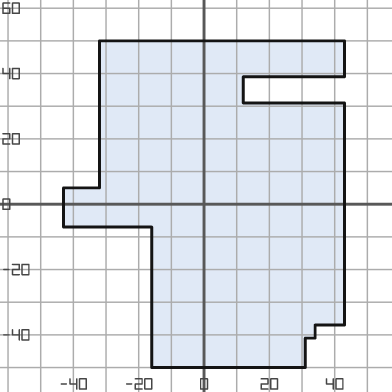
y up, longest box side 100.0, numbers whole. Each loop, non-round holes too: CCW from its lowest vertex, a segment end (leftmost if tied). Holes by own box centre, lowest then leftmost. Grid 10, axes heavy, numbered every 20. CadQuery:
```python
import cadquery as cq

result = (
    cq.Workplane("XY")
    .moveTo(-16.0, -50.0)
    .lineTo(31.0, -50.0)
    .lineTo(31.0, -41.0)
    .lineTo(34.0, -41.0)
    .lineTo(34.0, -37.0)
    .lineTo(43.0, -37.0)
    .lineTo(43.0, 31.0)
    .lineTo(12.0, 31.0)
    .lineTo(12.0, 39.0)
    .lineTo(43.0, 39.0)
    .lineTo(43.0, 50.0)
    .lineTo(-32.0, 50.0)
    .lineTo(-32.0, 5.0)
    .lineTo(-43.0, 5.0)
    .lineTo(-43.0, -7.0)
    .lineTo(-16.0, -7.0)
    .close()
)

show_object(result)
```